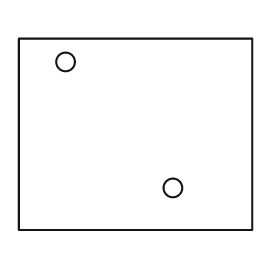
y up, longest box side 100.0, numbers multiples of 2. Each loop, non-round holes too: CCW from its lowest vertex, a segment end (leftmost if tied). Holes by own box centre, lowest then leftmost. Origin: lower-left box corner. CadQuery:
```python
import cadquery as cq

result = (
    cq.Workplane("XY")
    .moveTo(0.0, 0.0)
    .lineTo(100.0, 0.0)
    .lineTo(100.0, 82.0)
    .lineTo(0.0, 82.0)
    .close()
    .moveTo(66.0, 18.0)
    .circle(4.0)
    .moveTo(20.0, 72.0)
    .circle(4.0)
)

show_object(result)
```